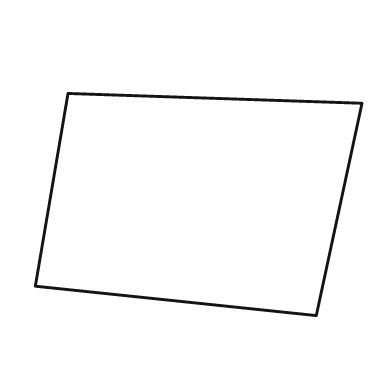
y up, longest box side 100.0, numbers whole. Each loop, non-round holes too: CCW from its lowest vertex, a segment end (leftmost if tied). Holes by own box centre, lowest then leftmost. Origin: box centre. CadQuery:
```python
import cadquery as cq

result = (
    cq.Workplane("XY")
    .moveTo(36.0, -34.0)
    .lineTo(50.0, 31.0)
    .lineTo(-40.0, 34.0)
    .lineTo(-50.0, -25.0)
    .close()
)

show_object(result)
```